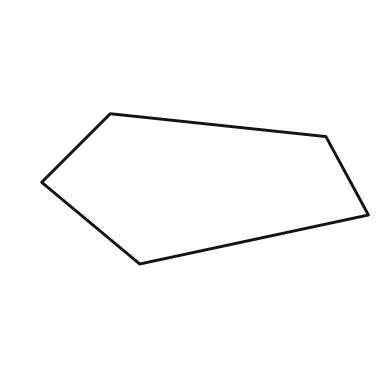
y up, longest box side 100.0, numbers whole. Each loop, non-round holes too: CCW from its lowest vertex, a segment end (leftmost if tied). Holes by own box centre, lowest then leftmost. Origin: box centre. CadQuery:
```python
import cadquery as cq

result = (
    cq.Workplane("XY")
    .moveTo(-20.0, -23.0)
    .lineTo(50.0, -8.0)
    .lineTo(37.0, 16.0)
    .lineTo(-29.0, 23.0)
    .lineTo(-50.0, 2.0)
    .close()
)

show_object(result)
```